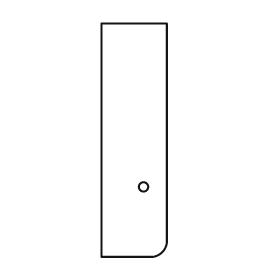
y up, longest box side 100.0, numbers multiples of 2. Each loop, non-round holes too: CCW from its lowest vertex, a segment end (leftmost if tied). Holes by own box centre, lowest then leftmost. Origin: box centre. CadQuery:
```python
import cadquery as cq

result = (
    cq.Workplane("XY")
    .moveTo(-14.0, -50.0)
    .lineTo(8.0, -50.0)
    .threePointArc((12.0, -48.0), (14.0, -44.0))
    .lineTo(14.0, 50.0)
    .lineTo(-14.0, 50.0)
    .close()
    .moveTo(4.0, -20.0)
    .circle(2.0)
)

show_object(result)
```